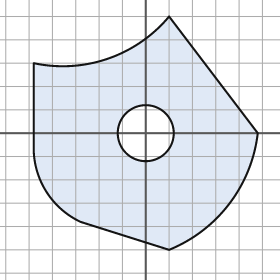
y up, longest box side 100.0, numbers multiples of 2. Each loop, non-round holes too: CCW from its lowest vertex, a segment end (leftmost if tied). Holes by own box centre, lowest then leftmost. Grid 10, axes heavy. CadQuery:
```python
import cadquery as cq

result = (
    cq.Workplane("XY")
    .moveTo(10.0, -50.0)
    .threePointArc((36.0, -30.0), (48.0, 0.0))
    .lineTo(10.0, 50.0)
    .threePointArc((-16.0, 32.0), (-48.0, 30.0))
    .lineTo(-48.0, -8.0)
    .threePointArc((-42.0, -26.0), (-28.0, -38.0))
    .close()
    .moveTo(0.0, 0.0)
    .circle(12.0)
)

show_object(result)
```